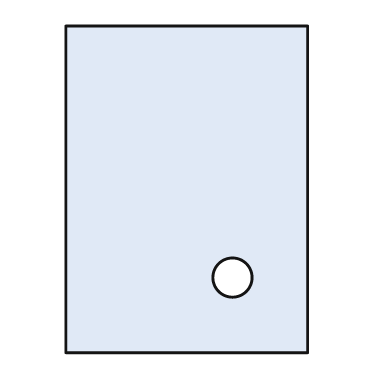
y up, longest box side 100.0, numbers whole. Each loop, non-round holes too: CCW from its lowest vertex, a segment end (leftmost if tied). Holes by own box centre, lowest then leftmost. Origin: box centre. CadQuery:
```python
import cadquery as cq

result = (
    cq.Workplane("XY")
    .moveTo(-37.0, -50.0)
    .lineTo(37.0, -50.0)
    .lineTo(37.0, 50.0)
    .lineTo(-37.0, 50.0)
    .close()
    .moveTo(14.0, -27.0)
    .circle(6.0)
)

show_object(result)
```